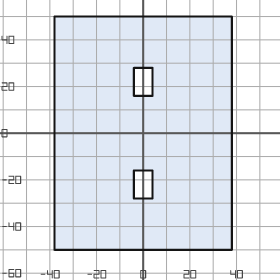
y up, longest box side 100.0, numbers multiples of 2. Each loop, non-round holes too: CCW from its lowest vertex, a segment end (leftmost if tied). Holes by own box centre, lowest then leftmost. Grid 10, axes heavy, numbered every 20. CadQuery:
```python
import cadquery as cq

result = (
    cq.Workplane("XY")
    .moveTo(-38.0, -50.0)
    .lineTo(38.0, -50.0)
    .lineTo(38.0, 50.0)
    .lineTo(-38.0, 50.0)
    .close()
    .moveTo(-4.0, -28.0)
    .lineTo(4.0, -28.0)
    .lineTo(4.0, -16.0)
    .lineTo(-4.0, -16.0)
    .close()
    .moveTo(-4.0, 16.0)
    .lineTo(4.0, 16.0)
    .lineTo(4.0, 28.0)
    .lineTo(-4.0, 28.0)
    .close()
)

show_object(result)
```